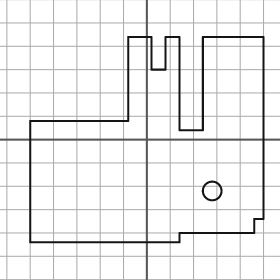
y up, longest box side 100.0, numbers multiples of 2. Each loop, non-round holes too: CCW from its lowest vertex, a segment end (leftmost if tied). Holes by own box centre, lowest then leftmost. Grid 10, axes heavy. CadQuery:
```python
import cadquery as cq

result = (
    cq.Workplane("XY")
    .moveTo(-50.0, -44.0)
    .lineTo(14.0, -44.0)
    .lineTo(14.0, -40.0)
    .lineTo(46.0, -40.0)
    .lineTo(46.0, -34.0)
    .lineTo(50.0, -34.0)
    .lineTo(50.0, 44.0)
    .lineTo(24.0, 44.0)
    .lineTo(24.0, 4.0)
    .lineTo(14.0, 4.0)
    .lineTo(14.0, 44.0)
    .lineTo(8.0, 44.0)
    .lineTo(8.0, 30.0)
    .lineTo(2.0, 30.0)
    .lineTo(2.0, 44.0)
    .lineTo(-8.0, 44.0)
    .lineTo(-8.0, 8.0)
    .lineTo(-50.0, 8.0)
    .close()
    .moveTo(28.0, -22.0)
    .circle(4.0)
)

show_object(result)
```